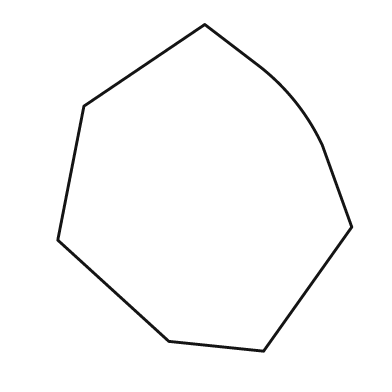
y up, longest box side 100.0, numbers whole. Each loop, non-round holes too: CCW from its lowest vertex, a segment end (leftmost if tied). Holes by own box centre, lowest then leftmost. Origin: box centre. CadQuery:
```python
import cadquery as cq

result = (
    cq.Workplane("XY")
    .moveTo(18.0, -50.0)
    .lineTo(45.0, -12.0)
    .lineTo(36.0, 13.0)
    .threePointArc((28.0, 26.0), (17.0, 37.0))
    .lineTo(0.0, 50.0)
    .lineTo(-37.0, 25.0)
    .lineTo(-45.0, -16.0)
    .lineTo(-11.0, -47.0)
    .close()
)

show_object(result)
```